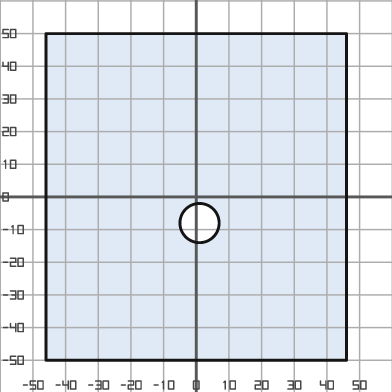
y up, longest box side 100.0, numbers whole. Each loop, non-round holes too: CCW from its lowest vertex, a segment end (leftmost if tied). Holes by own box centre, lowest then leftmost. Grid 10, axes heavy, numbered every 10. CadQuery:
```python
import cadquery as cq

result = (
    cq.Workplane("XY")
    .moveTo(-46.0, -50.0)
    .lineTo(46.0, -50.0)
    .lineTo(46.0, 50.0)
    .lineTo(-46.0, 50.0)
    .close()
    .moveTo(1.0, -8.0)
    .circle(6.0)
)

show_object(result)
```